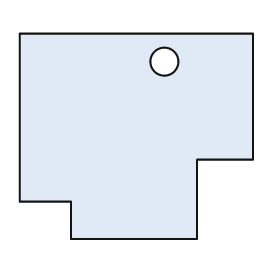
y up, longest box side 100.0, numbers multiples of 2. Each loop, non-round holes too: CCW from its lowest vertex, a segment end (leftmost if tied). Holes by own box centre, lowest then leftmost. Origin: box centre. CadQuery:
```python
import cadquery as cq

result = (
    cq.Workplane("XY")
    .moveTo(-28.0, -44.0)
    .lineTo(26.0, -44.0)
    .lineTo(26.0, -10.0)
    .lineTo(50.0, -10.0)
    .lineTo(50.0, 44.0)
    .lineTo(-50.0, 44.0)
    .lineTo(-50.0, -28.0)
    .lineTo(-28.0, -28.0)
    .close()
    .moveTo(12.0, 32.0)
    .circle(6.0)
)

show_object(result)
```